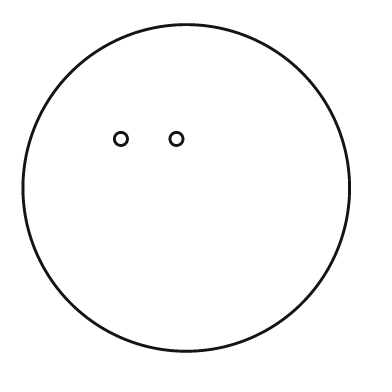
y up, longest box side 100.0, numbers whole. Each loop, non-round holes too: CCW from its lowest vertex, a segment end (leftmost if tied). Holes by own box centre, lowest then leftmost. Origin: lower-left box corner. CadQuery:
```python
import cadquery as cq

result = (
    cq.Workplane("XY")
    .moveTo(50.0, 50.0)
    .circle(50.0)
    .moveTo(30.0, 65.0)
    .circle(2.0)
    .moveTo(47.0, 65.0)
    .circle(2.0)
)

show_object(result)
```